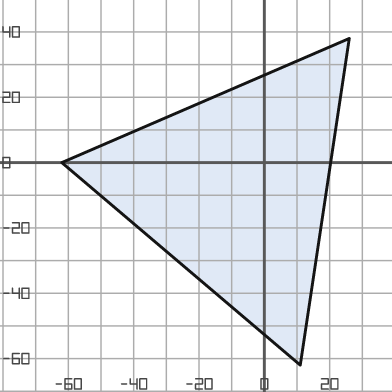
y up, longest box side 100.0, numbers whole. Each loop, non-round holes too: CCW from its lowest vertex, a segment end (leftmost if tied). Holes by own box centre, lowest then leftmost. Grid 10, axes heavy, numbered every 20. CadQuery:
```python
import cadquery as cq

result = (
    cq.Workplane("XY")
    .moveTo(11.0, -62.0)
    .lineTo(26.0, 38.0)
    .lineTo(-62.0, 0.0)
    .close()
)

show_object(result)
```